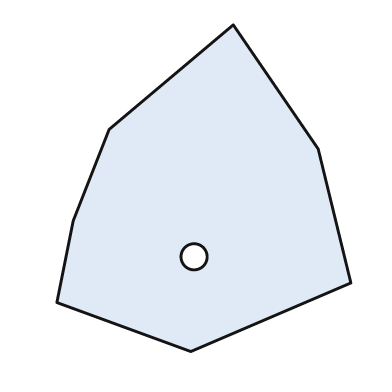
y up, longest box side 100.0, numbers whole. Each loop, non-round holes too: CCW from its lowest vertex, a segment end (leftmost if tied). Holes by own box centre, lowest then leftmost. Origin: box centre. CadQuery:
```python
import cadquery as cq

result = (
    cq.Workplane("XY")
    .moveTo(-4.0, -50.0)
    .lineTo(45.0, -29.0)
    .lineTo(35.0, 12.0)
    .lineTo(9.0, 50.0)
    .lineTo(-29.0, 18.0)
    .lineTo(-40.0, -10.0)
    .lineTo(-45.0, -35.0)
    .close()
    .moveTo(-3.0, -21.0)
    .circle(4.0)
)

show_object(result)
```